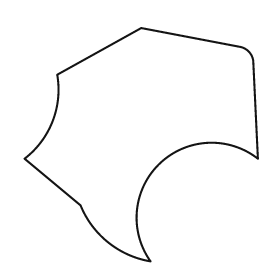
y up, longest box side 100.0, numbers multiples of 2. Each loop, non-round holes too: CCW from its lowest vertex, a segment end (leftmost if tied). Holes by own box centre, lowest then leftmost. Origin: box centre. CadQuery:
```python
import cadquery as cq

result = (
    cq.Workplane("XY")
    .moveTo(4.0, -50.0)
    .threePointArc((8.0, -8.0), (50.0, -6.0))
    .lineTo(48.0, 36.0)
    .threePointArc((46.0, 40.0), (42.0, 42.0))
    .lineTo(0.0, 50.0)
    .lineTo(-36.0, 30.0)
    .threePointArc((-38.0, 10.0), (-50.0, -6.0))
    .lineTo(-26.0, -26.0)
    .threePointArc((-14.0, -42.0), (4.0, -50.0))
    .close()
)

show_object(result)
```